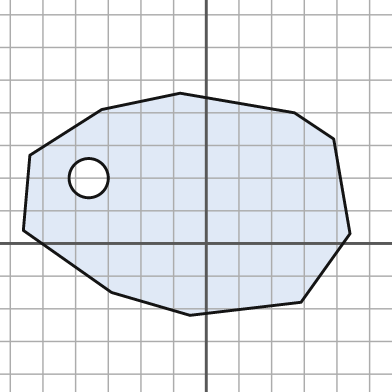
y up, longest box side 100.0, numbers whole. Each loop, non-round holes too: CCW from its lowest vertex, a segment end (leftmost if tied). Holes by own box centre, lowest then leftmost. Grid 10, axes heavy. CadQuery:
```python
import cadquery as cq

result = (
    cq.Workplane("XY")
    .moveTo(-5.0, -22.0)
    .lineTo(29.0, -18.0)
    .lineTo(44.0, 3.0)
    .lineTo(39.0, 32.0)
    .lineTo(27.0, 40.0)
    .lineTo(-8.0, 46.0)
    .lineTo(-32.0, 41.0)
    .lineTo(-54.0, 27.0)
    .lineTo(-56.0, 4.0)
    .lineTo(-29.0, -15.0)
    .close()
    .moveTo(-36.0, 20.0)
    .circle(6.0)
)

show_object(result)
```